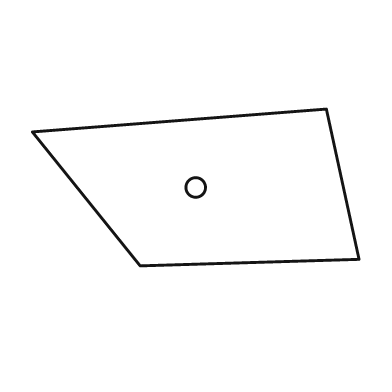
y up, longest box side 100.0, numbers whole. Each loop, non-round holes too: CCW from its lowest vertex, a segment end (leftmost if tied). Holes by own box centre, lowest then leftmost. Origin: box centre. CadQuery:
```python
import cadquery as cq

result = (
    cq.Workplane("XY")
    .moveTo(-17.0, -24.0)
    .lineTo(50.0, -22.0)
    .lineTo(40.0, 24.0)
    .lineTo(-50.0, 17.0)
    .close()
    .moveTo(0.0, 0.0)
    .circle(3.0)
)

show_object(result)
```